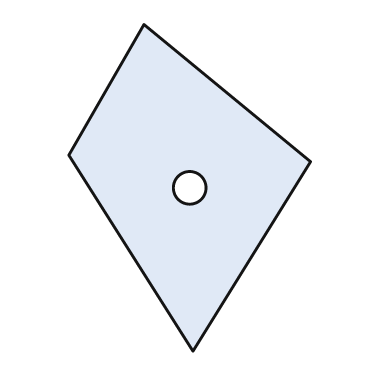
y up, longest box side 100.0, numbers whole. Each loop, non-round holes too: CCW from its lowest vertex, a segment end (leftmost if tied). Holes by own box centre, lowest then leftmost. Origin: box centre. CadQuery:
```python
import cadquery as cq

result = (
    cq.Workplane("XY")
    .moveTo(1.0, -50.0)
    .lineTo(37.0, 8.0)
    .lineTo(-14.0, 50.0)
    .lineTo(-37.0, 10.0)
    .close()
    .moveTo(0.0, 0.0)
    .circle(5.0)
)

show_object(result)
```